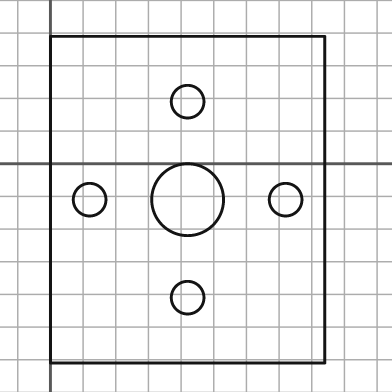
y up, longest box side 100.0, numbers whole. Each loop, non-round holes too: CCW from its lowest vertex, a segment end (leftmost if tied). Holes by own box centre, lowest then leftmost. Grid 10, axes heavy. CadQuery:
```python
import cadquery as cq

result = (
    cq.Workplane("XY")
    .moveTo(0.0, -61.0)
    .lineTo(84.0, -61.0)
    .lineTo(84.0, 39.0)
    .lineTo(0.0, 39.0)
    .close()
    .moveTo(42.0, -41.0)
    .circle(5.0)
    .moveTo(12.0, -11.0)
    .circle(5.0)
    .moveTo(42.0, -11.0)
    .circle(11.0)
    .moveTo(72.0, -11.0)
    .circle(5.0)
    .moveTo(42.0, 19.0)
    .circle(5.0)
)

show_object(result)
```